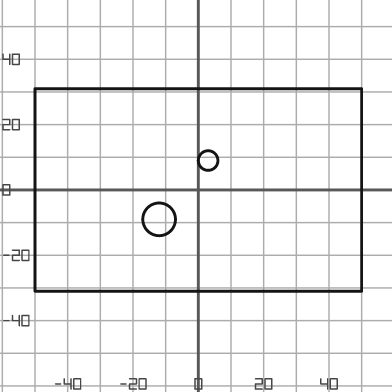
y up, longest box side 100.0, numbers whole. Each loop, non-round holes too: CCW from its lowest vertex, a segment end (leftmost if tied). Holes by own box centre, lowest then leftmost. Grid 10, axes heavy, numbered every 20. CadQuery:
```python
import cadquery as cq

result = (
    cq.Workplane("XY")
    .moveTo(-50.0, -31.0)
    .lineTo(50.0, -31.0)
    .lineTo(50.0, 31.0)
    .lineTo(-50.0, 31.0)
    .close()
    .moveTo(-12.0, -9.0)
    .circle(5.0)
    .moveTo(3.0, 9.0)
    .circle(3.0)
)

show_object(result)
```